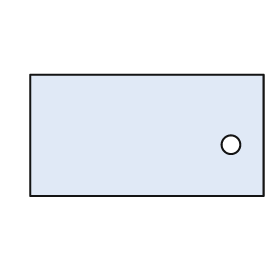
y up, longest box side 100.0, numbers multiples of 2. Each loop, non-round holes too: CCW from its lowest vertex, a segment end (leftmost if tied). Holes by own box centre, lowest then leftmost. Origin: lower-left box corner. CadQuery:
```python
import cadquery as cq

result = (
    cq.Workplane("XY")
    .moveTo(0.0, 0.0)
    .lineTo(100.0, 0.0)
    .lineTo(100.0, 52.0)
    .lineTo(0.0, 52.0)
    .close()
    .moveTo(86.0, 22.0)
    .circle(4.0)
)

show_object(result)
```